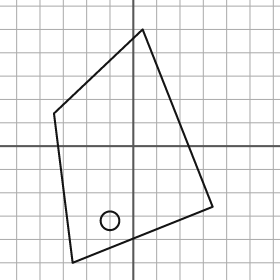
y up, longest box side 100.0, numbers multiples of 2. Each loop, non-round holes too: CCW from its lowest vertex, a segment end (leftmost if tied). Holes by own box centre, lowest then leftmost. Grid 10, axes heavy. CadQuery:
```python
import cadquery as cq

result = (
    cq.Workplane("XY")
    .moveTo(-26.0, -50.0)
    .lineTo(34.0, -26.0)
    .lineTo(4.0, 50.0)
    .lineTo(-34.0, 14.0)
    .close()
    .moveTo(-10.0, -32.0)
    .circle(4.0)
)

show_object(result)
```